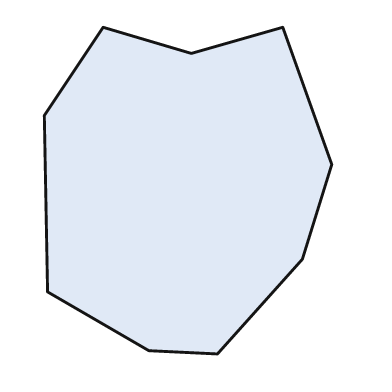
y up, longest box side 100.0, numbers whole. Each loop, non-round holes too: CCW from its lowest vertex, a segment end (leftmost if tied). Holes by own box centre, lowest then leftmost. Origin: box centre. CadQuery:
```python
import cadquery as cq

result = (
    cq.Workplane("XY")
    .moveTo(9.0, -50.0)
    .lineTo(35.0, -21.0)
    .lineTo(44.0, 8.0)
    .lineTo(29.0, 50.0)
    .lineTo(1.0, 42.0)
    .lineTo(-26.0, 50.0)
    .lineTo(-44.0, 23.0)
    .lineTo(-43.0, -31.0)
    .lineTo(-12.0, -49.0)
    .close()
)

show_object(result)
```